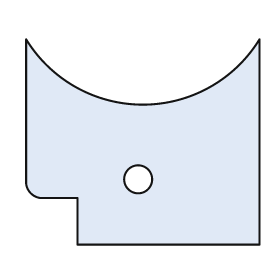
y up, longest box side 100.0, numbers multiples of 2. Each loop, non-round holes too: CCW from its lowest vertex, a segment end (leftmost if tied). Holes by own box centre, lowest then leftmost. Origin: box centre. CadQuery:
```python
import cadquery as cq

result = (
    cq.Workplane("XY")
    .moveTo(-28.0, -44.0)
    .lineTo(50.0, -44.0)
    .lineTo(50.0, 44.0)
    .threePointArc((0.0, 16.0), (-50.0, 44.0))
    .lineTo(-50.0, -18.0)
    .threePointArc((-48.0, -22.0), (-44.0, -24.0))
    .lineTo(-28.0, -24.0)
    .close()
    .moveTo(-2.0, -16.0)
    .circle(6.0)
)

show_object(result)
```